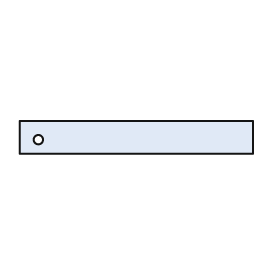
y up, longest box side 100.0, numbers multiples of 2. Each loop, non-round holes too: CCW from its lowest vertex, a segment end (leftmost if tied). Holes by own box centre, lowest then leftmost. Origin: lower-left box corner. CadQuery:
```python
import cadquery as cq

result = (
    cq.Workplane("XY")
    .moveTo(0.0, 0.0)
    .lineTo(100.0, 0.0)
    .lineTo(100.0, 14.0)
    .lineTo(0.0, 14.0)
    .close()
    .moveTo(8.0, 6.0)
    .circle(2.0)
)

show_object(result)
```